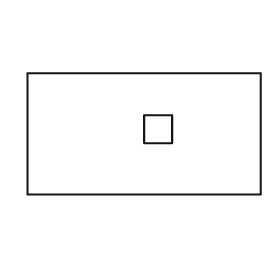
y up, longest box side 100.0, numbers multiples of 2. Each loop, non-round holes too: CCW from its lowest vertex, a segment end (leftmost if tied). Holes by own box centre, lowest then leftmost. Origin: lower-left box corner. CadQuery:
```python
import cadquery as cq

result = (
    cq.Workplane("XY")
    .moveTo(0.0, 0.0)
    .lineTo(100.0, 0.0)
    .lineTo(100.0, 52.0)
    .lineTo(0.0, 52.0)
    .close()
    .moveTo(50.0, 22.0)
    .lineTo(62.0, 22.0)
    .lineTo(62.0, 34.0)
    .lineTo(50.0, 34.0)
    .close()
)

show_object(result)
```